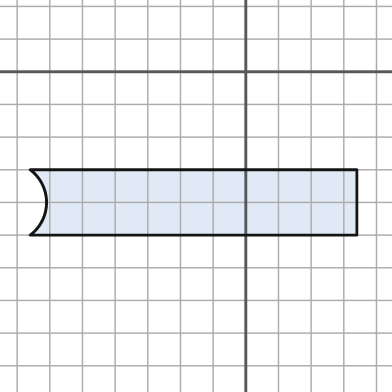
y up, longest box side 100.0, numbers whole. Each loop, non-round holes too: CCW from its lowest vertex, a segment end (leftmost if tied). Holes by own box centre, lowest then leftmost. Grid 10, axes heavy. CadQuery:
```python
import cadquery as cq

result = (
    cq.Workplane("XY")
    .moveTo(-66.0, -50.0)
    .lineTo(34.0, -50.0)
    .lineTo(34.0, -30.0)
    .lineTo(-66.0, -30.0)
    .threePointArc((-61.0, -40.0), (-66.0, -50.0))
    .close()
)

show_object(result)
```